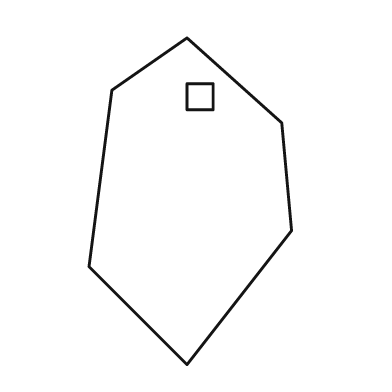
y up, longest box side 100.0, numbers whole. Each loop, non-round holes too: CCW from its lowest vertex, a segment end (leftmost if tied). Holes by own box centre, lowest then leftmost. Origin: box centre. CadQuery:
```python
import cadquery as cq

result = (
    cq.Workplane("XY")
    .moveTo(-1.0, -50.0)
    .lineTo(31.0, -9.0)
    .lineTo(28.0, 24.0)
    .lineTo(-1.0, 50.0)
    .lineTo(-24.0, 34.0)
    .lineTo(-31.0, -20.0)
    .close()
    .moveTo(-1.0, 28.0)
    .lineTo(7.0, 28.0)
    .lineTo(7.0, 36.0)
    .lineTo(-1.0, 36.0)
    .close()
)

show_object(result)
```